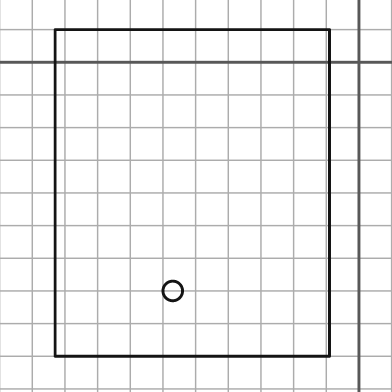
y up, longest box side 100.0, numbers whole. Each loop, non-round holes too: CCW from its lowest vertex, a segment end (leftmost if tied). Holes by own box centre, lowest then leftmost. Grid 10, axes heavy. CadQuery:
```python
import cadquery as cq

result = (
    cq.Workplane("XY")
    .moveTo(-93.0, -90.0)
    .lineTo(-9.0, -90.0)
    .lineTo(-9.0, 10.0)
    .lineTo(-93.0, 10.0)
    .close()
    .moveTo(-57.0, -70.0)
    .circle(3.0)
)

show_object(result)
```